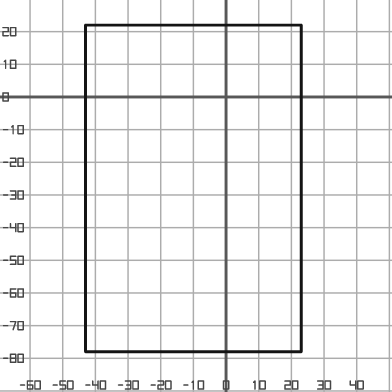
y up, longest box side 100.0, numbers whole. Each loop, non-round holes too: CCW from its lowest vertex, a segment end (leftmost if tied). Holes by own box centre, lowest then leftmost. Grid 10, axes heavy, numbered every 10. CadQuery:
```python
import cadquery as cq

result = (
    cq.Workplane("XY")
    .moveTo(-43.0, -78.0)
    .lineTo(23.0, -78.0)
    .lineTo(23.0, 22.0)
    .lineTo(-43.0, 22.0)
    .close()
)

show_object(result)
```